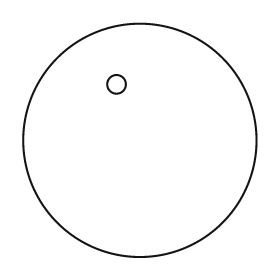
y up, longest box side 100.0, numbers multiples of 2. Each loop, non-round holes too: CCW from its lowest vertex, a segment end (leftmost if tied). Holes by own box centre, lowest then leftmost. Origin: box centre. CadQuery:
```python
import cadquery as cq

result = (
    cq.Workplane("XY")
    .moveTo(0.0, 0.0)
    .circle(50.0)
    .moveTo(-10.0, 24.0)
    .circle(4.0)
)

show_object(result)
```